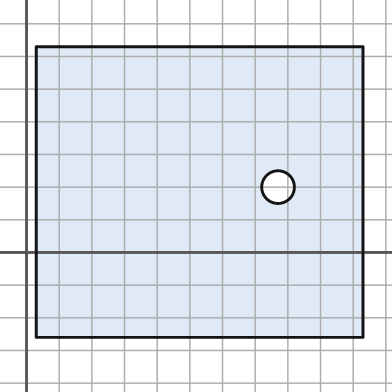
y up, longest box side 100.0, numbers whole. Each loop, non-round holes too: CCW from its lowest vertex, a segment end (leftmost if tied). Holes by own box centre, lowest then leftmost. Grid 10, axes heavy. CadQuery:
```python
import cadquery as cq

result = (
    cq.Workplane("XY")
    .moveTo(3.0, -26.0)
    .lineTo(103.0, -26.0)
    .lineTo(103.0, 63.0)
    .lineTo(3.0, 63.0)
    .close()
    .moveTo(77.0, 20.0)
    .circle(5.0)
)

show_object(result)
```